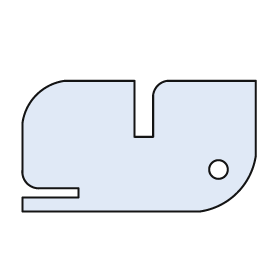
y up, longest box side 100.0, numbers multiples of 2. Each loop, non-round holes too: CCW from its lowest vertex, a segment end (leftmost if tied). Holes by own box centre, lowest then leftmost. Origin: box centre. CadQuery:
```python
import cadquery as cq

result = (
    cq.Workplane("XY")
    .moveTo(-50.0, -28.0)
    .lineTo(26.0, -28.0)
    .threePointArc((42.0, -20.0), (50.0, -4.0))
    .lineTo(50.0, 28.0)
    .lineTo(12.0, 28.0)
    .threePointArc((8.0, 26.0), (6.0, 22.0))
    .lineTo(6.0, 4.0)
    .lineTo(-2.0, 4.0)
    .lineTo(-2.0, 28.0)
    .lineTo(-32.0, 28.0)
    .threePointArc((-44.0, 22.0), (-50.0, 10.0))
    .lineTo(-50.0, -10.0)
    .threePointArc((-48.0, -16.0), (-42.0, -18.0))
    .lineTo(-26.0, -18.0)
    .lineTo(-26.0, -22.0)
    .lineTo(-50.0, -22.0)
    .close()
    .moveTo(34.0, -10.0)
    .circle(4.0)
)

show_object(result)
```